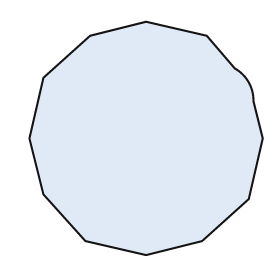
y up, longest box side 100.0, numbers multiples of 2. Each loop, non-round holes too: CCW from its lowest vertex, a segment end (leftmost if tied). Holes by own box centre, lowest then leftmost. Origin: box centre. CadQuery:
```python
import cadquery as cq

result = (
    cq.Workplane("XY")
    .moveTo(0.0, -50.0)
    .lineTo(24.0, -44.0)
    .lineTo(44.0, -26.0)
    .lineTo(50.0, 0.0)
    .lineTo(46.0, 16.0)
    .threePointArc((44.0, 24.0), (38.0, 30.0))
    .lineTo(26.0, 44.0)
    .lineTo(0.0, 50.0)
    .lineTo(-24.0, 44.0)
    .lineTo(-44.0, 26.0)
    .lineTo(-50.0, 0.0)
    .lineTo(-44.0, -24.0)
    .lineTo(-26.0, -44.0)
    .close()
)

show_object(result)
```